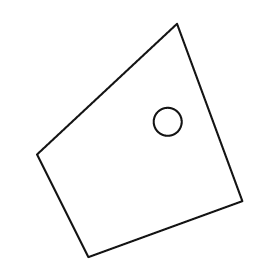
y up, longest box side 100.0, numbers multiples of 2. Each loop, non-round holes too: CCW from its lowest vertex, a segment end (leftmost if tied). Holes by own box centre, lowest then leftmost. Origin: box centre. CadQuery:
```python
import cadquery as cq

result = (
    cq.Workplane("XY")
    .moveTo(-22.0, -50.0)
    .lineTo(44.0, -26.0)
    .lineTo(16.0, 50.0)
    .lineTo(-44.0, -6.0)
    .close()
    .moveTo(12.0, 8.0)
    .circle(6.0)
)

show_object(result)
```